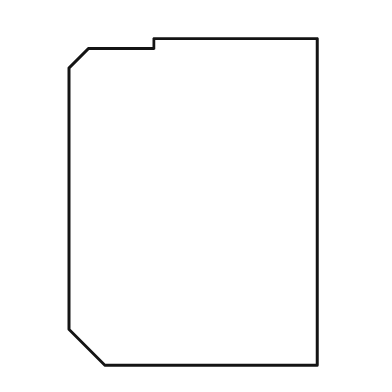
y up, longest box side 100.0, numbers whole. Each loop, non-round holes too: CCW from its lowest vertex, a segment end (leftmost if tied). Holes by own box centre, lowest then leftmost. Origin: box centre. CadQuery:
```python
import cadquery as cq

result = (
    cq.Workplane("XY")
    .moveTo(-27.0, -50.0)
    .lineTo(38.0, -50.0)
    .lineTo(38.0, 50.0)
    .lineTo(-12.0, 50.0)
    .lineTo(-12.0, 47.0)
    .lineTo(-32.0, 47.0)
    .lineTo(-38.0, 41.0)
    .lineTo(-38.0, -39.0)
    .close()
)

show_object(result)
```